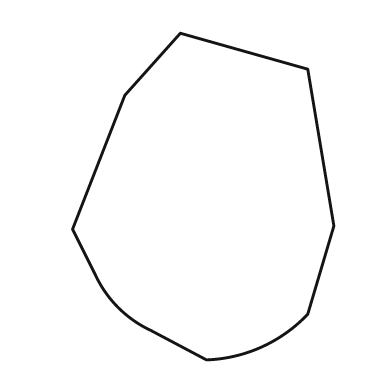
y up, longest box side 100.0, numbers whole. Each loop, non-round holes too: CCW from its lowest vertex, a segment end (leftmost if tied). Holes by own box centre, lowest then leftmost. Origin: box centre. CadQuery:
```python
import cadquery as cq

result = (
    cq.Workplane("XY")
    .moveTo(1.0, -50.0)
    .threePointArc((18.0, -46.0), (32.0, -36.0))
    .lineTo(40.0, -9.0)
    .lineTo(32.0, 39.0)
    .lineTo(-7.0, 50.0)
    .lineTo(-24.0, 31.0)
    .lineTo(-40.0, -10.0)
    .lineTo(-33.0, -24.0)
    .threePointArc((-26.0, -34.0), (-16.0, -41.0))
    .close()
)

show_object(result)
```